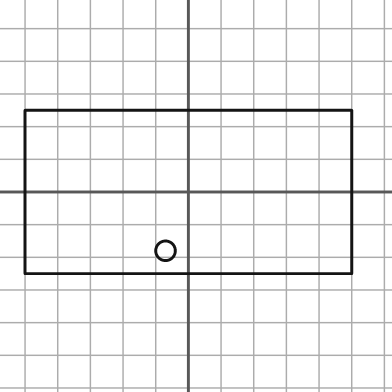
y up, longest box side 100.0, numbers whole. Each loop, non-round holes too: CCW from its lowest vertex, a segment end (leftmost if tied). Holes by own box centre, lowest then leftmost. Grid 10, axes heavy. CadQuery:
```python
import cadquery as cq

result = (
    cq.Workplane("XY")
    .moveTo(-50.0, -25.0)
    .lineTo(50.0, -25.0)
    .lineTo(50.0, 25.0)
    .lineTo(-50.0, 25.0)
    .close()
    .moveTo(-7.0, -18.0)
    .circle(3.0)
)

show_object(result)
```